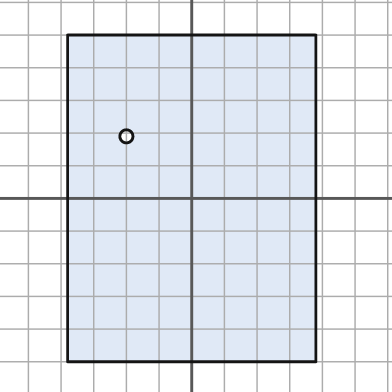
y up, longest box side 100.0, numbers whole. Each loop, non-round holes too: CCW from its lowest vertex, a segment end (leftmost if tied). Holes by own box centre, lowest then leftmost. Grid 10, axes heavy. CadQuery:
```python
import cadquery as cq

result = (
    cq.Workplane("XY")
    .moveTo(-38.0, -50.0)
    .lineTo(38.0, -50.0)
    .lineTo(38.0, 50.0)
    .lineTo(-38.0, 50.0)
    .close()
    .moveTo(-20.0, 19.0)
    .circle(2.0)
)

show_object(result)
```